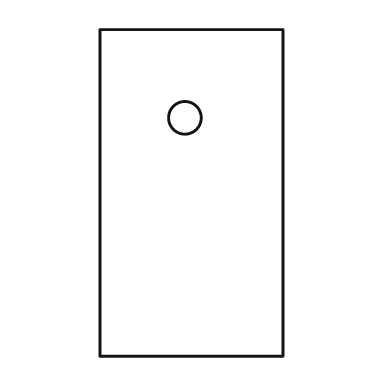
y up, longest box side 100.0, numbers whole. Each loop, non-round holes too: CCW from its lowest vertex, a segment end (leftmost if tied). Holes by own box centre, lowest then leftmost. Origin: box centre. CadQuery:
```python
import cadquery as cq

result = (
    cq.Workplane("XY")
    .moveTo(-28.0, -50.0)
    .lineTo(28.0, -50.0)
    .lineTo(28.0, 50.0)
    .lineTo(-28.0, 50.0)
    .close()
    .moveTo(-2.0, 23.0)
    .circle(5.0)
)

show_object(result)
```